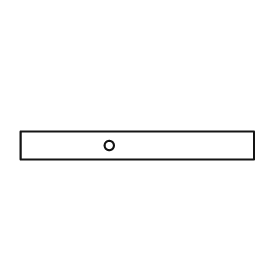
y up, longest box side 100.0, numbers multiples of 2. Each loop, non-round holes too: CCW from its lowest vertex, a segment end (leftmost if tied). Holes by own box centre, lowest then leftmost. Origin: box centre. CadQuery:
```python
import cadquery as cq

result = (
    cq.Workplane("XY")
    .moveTo(-50.0, -6.0)
    .lineTo(50.0, -6.0)
    .lineTo(50.0, 6.0)
    .lineTo(-50.0, 6.0)
    .close()
    .moveTo(-12.0, 0.0)
    .circle(2.0)
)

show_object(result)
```